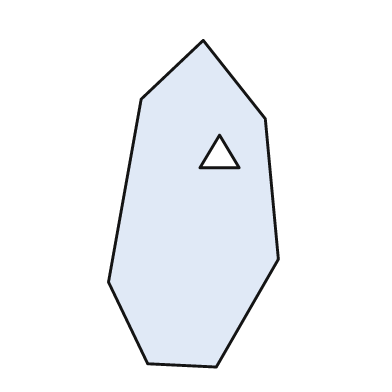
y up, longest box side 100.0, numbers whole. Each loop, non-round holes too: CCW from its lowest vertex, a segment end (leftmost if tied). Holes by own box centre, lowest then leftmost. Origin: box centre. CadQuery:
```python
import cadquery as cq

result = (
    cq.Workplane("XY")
    .moveTo(7.0, -50.0)
    .lineTo(26.0, -17.0)
    .lineTo(22.0, 26.0)
    .lineTo(3.0, 50.0)
    .lineTo(-16.0, 32.0)
    .lineTo(-26.0, -24.0)
    .lineTo(-14.0, -49.0)
    .close()
    .moveTo(2.0, 11.0)
    .lineTo(14.0, 11.0)
    .lineTo(8.0, 21.0)
    .close()
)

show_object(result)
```